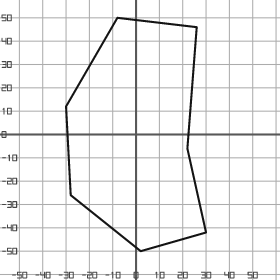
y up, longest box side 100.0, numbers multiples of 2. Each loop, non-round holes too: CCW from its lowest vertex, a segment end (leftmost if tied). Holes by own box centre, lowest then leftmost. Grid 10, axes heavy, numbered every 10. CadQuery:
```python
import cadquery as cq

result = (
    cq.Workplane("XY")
    .moveTo(2.0, -50.0)
    .lineTo(30.0, -42.0)
    .lineTo(22.0, -6.0)
    .lineTo(26.0, 46.0)
    .lineTo(-8.0, 50.0)
    .lineTo(-30.0, 12.0)
    .lineTo(-28.0, -26.0)
    .close()
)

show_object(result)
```